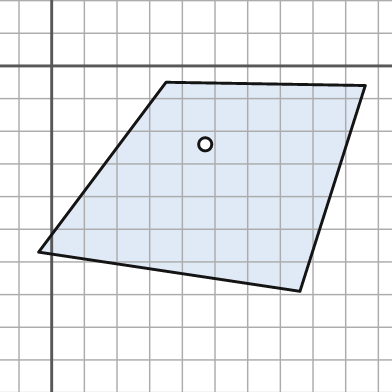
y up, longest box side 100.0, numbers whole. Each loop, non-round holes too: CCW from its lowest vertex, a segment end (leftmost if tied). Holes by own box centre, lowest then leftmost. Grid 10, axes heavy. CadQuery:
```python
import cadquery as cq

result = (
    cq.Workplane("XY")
    .moveTo(76.0, -69.0)
    .lineTo(96.0, -6.0)
    .lineTo(35.0, -5.0)
    .lineTo(-4.0, -57.0)
    .close()
    .moveTo(47.0, -24.0)
    .circle(2.0)
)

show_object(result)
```